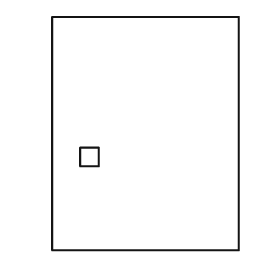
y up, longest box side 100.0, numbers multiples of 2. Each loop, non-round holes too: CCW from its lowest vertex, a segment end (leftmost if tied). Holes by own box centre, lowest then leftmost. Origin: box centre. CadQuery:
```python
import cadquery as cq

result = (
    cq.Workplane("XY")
    .moveTo(-40.0, -50.0)
    .lineTo(40.0, -50.0)
    .lineTo(40.0, 50.0)
    .lineTo(-40.0, 50.0)
    .close()
    .moveTo(-28.0, -14.0)
    .lineTo(-20.0, -14.0)
    .lineTo(-20.0, -6.0)
    .lineTo(-28.0, -6.0)
    .close()
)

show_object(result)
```